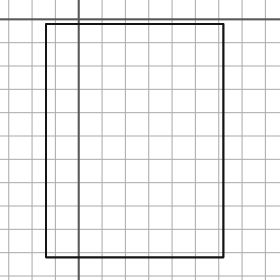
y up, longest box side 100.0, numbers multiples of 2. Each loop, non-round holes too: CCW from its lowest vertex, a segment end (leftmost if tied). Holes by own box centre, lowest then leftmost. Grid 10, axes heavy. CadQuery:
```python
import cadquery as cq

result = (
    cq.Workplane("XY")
    .moveTo(-14.0, -102.0)
    .lineTo(62.0, -102.0)
    .lineTo(62.0, -2.0)
    .lineTo(-14.0, -2.0)
    .close()
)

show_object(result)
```